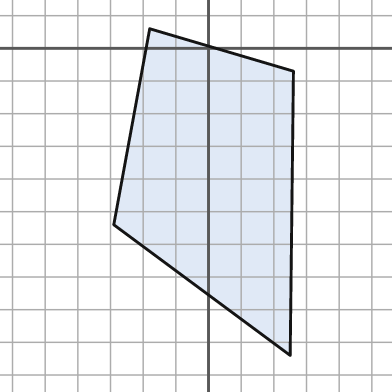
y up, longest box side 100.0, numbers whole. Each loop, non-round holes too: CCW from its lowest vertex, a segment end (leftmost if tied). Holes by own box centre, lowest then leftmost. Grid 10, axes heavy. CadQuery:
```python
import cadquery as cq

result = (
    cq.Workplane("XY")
    .moveTo(25.0, -94.0)
    .lineTo(26.0, -7.0)
    .lineTo(-18.0, 6.0)
    .lineTo(-29.0, -54.0)
    .close()
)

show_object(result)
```